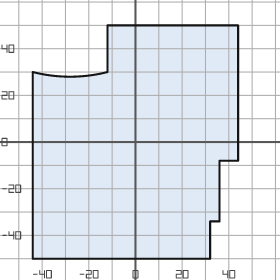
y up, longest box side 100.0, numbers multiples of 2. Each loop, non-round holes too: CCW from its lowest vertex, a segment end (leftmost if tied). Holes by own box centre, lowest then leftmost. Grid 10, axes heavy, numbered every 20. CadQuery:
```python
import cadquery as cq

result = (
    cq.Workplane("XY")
    .moveTo(-44.0, -50.0)
    .lineTo(32.0, -50.0)
    .lineTo(32.0, -34.0)
    .lineTo(36.0, -34.0)
    .lineTo(36.0, -8.0)
    .lineTo(44.0, -8.0)
    .lineTo(44.0, 50.0)
    .lineTo(-12.0, 50.0)
    .lineTo(-12.0, 30.0)
    .threePointArc((-28.0, 28.0), (-44.0, 30.0))
    .close()
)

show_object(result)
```